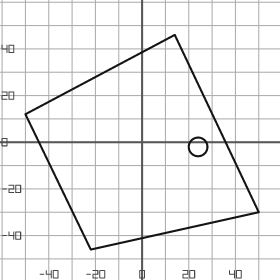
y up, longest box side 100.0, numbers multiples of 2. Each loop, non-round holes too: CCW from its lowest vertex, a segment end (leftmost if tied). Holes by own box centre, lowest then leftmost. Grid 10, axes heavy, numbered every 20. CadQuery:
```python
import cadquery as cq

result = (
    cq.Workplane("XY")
    .moveTo(-22.0, -46.0)
    .lineTo(50.0, -30.0)
    .lineTo(14.0, 46.0)
    .lineTo(-50.0, 12.0)
    .close()
    .moveTo(24.0, -2.0)
    .circle(4.0)
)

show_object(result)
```